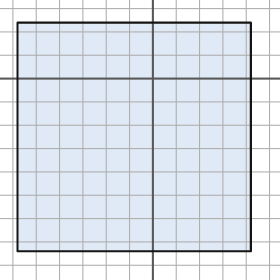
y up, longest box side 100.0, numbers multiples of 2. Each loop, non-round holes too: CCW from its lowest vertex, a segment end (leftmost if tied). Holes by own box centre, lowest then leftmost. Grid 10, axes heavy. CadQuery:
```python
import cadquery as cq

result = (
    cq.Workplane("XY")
    .moveTo(-58.0, -74.0)
    .lineTo(42.0, -74.0)
    .lineTo(42.0, 24.0)
    .lineTo(-58.0, 24.0)
    .close()
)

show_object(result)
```